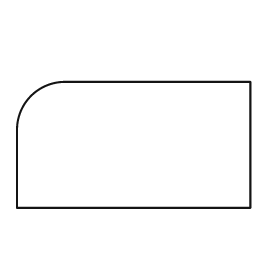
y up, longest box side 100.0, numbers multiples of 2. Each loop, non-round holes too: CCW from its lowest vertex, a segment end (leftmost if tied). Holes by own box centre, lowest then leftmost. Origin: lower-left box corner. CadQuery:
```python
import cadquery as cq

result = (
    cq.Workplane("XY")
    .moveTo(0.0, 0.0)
    .lineTo(100.0, 0.0)
    .lineTo(100.0, 54.0)
    .lineTo(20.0, 54.0)
    .threePointArc((6.0, 48.0), (0.0, 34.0))
    .close()
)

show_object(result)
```